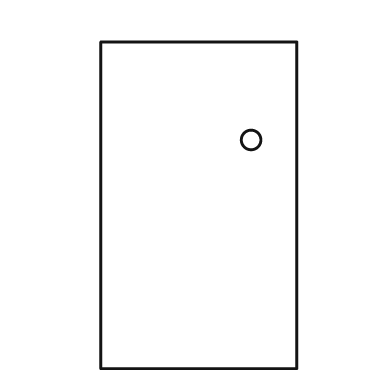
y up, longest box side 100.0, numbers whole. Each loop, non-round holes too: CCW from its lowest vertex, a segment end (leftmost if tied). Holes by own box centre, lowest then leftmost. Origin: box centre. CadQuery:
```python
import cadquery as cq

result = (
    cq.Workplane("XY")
    .moveTo(-30.0, -50.0)
    .lineTo(30.0, -50.0)
    .lineTo(30.0, 50.0)
    .lineTo(-30.0, 50.0)
    .close()
    .moveTo(16.0, 20.0)
    .circle(3.0)
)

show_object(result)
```